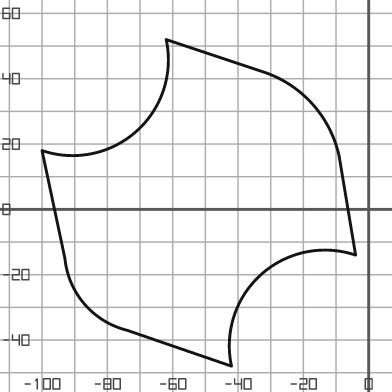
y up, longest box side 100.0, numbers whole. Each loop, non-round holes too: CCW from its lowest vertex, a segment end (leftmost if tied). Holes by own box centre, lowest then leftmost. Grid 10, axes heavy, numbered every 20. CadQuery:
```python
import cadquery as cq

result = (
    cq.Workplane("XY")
    .moveTo(-42.0, -48.0)
    .threePointArc((-33.0, -20.0), (-4.0, -14.0))
    .lineTo(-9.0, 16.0)
    .threePointArc((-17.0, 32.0), (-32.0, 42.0))
    .lineTo(-62.0, 52.0)
    .threePointArc((-71.0, 24.0), (-100.0, 18.0))
    .lineTo(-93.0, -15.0)
    .threePointArc((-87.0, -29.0), (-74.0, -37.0))
    .close()
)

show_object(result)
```